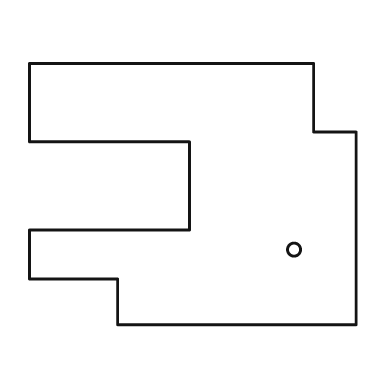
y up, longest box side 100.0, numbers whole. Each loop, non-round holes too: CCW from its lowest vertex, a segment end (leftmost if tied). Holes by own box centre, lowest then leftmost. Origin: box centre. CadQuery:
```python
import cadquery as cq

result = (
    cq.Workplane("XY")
    .moveTo(-23.0, -40.0)
    .lineTo(50.0, -40.0)
    .lineTo(50.0, 19.0)
    .lineTo(37.0, 19.0)
    .lineTo(37.0, 40.0)
    .lineTo(-50.0, 40.0)
    .lineTo(-50.0, 16.0)
    .lineTo(-1.0, 16.0)
    .lineTo(-1.0, -11.0)
    .lineTo(-50.0, -11.0)
    .lineTo(-50.0, -26.0)
    .lineTo(-23.0, -26.0)
    .close()
    .moveTo(31.0, -17.0)
    .circle(2.0)
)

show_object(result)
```